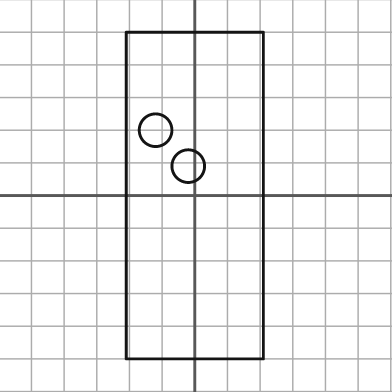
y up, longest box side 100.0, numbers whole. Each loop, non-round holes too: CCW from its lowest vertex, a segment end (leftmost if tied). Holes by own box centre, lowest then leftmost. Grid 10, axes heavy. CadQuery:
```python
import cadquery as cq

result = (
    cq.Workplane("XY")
    .moveTo(-21.0, -50.0)
    .lineTo(21.0, -50.0)
    .lineTo(21.0, 50.0)
    .lineTo(-21.0, 50.0)
    .close()
    .moveTo(-2.0, 9.0)
    .circle(5.0)
    .moveTo(-12.0, 20.0)
    .circle(5.0)
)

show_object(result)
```